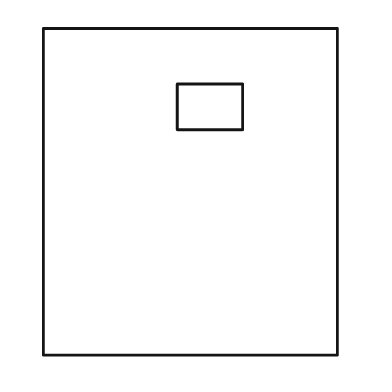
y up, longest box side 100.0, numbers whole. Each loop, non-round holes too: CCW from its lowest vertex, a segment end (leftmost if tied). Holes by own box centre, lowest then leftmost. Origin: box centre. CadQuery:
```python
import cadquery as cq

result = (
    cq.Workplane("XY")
    .moveTo(-45.0, -50.0)
    .lineTo(45.0, -50.0)
    .lineTo(45.0, 50.0)
    .lineTo(-45.0, 50.0)
    .close()
    .moveTo(-4.0, 19.0)
    .lineTo(16.0, 19.0)
    .lineTo(16.0, 33.0)
    .lineTo(-4.0, 33.0)
    .close()
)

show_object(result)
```